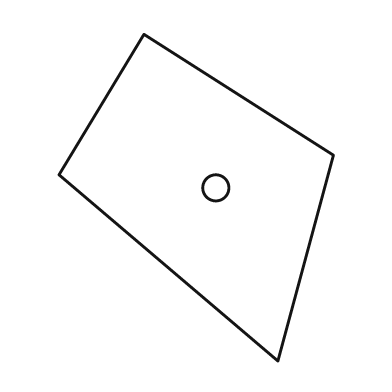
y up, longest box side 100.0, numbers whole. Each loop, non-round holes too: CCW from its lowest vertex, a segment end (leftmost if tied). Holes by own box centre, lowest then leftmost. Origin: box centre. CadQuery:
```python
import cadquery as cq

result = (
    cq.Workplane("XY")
    .moveTo(25.0, -50.0)
    .lineTo(42.0, 13.0)
    .lineTo(-16.0, 50.0)
    .lineTo(-42.0, 7.0)
    .close()
    .moveTo(6.0, 3.0)
    .circle(4.0)
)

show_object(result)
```